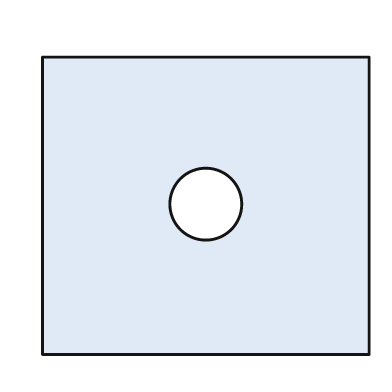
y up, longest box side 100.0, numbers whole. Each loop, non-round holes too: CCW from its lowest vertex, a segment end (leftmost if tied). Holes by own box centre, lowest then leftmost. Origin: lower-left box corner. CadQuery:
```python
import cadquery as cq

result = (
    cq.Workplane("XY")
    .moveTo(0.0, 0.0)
    .lineTo(100.0, 0.0)
    .lineTo(100.0, 91.0)
    .lineTo(0.0, 91.0)
    .close()
    .moveTo(50.0, 46.0)
    .circle(11.0)
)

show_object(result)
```